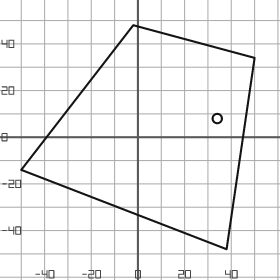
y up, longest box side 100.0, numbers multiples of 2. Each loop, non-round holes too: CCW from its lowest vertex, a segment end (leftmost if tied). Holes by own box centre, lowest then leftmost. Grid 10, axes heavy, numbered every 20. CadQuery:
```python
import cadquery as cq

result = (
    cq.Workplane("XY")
    .moveTo(38.0, -48.0)
    .lineTo(50.0, 34.0)
    .lineTo(-2.0, 48.0)
    .lineTo(-50.0, -14.0)
    .close()
    .moveTo(34.0, 8.0)
    .circle(2.0)
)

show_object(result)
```